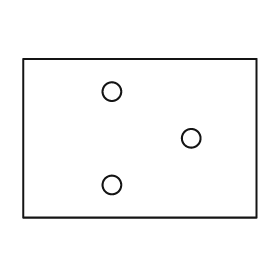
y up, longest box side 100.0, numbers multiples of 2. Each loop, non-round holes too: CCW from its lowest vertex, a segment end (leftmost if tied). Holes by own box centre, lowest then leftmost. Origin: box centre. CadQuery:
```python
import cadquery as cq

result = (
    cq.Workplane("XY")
    .moveTo(-50.0, -34.0)
    .lineTo(50.0, -34.0)
    .lineTo(50.0, 34.0)
    .lineTo(-50.0, 34.0)
    .close()
    .moveTo(-12.0, -20.0)
    .circle(4.0)
    .moveTo(22.0, 0.0)
    .circle(4.0)
    .moveTo(-12.0, 20.0)
    .circle(4.0)
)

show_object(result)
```